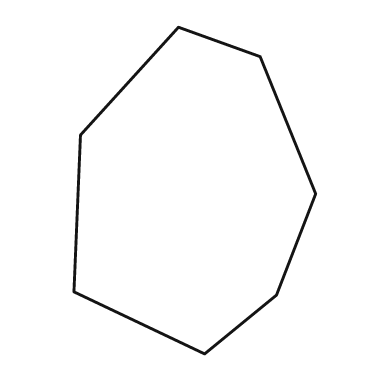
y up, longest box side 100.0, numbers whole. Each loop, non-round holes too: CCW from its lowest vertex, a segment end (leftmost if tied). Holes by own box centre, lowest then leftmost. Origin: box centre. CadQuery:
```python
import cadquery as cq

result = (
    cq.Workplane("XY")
    .moveTo(3.0, -50.0)
    .lineTo(25.0, -32.0)
    .lineTo(37.0, -1.0)
    .lineTo(20.0, 41.0)
    .lineTo(-5.0, 50.0)
    .lineTo(-35.0, 17.0)
    .lineTo(-37.0, -31.0)
    .close()
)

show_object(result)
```